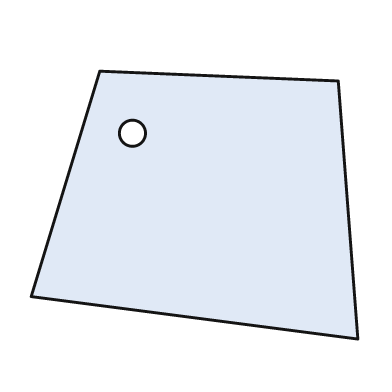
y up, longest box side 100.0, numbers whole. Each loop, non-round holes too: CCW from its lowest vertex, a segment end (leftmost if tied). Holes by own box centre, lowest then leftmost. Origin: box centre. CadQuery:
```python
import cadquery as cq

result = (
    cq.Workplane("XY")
    .moveTo(50.0, -41.0)
    .lineTo(44.0, 38.0)
    .lineTo(-29.0, 41.0)
    .lineTo(-50.0, -28.0)
    .close()
    .moveTo(-19.0, 22.0)
    .circle(4.0)
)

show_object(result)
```